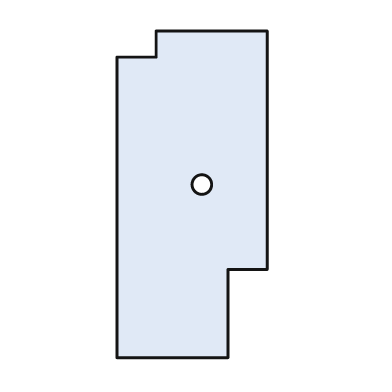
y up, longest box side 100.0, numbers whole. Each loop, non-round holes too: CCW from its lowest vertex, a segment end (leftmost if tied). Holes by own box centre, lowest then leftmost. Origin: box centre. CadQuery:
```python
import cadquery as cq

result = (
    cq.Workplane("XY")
    .moveTo(-23.0, -50.0)
    .lineTo(11.0, -50.0)
    .lineTo(11.0, -23.0)
    .lineTo(23.0, -23.0)
    .lineTo(23.0, 50.0)
    .lineTo(-11.0, 50.0)
    .lineTo(-11.0, 42.0)
    .lineTo(-23.0, 42.0)
    .close()
    .moveTo(3.0, 3.0)
    .circle(3.0)
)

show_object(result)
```